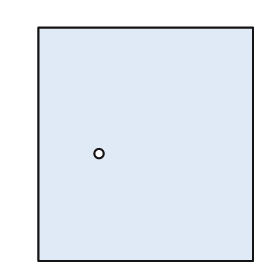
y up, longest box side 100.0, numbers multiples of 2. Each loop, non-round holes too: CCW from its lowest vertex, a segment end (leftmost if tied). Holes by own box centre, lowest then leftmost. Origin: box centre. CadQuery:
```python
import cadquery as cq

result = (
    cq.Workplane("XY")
    .moveTo(-46.0, -50.0)
    .lineTo(46.0, -50.0)
    .lineTo(46.0, 50.0)
    .lineTo(-46.0, 50.0)
    .close()
    .moveTo(-20.0, -4.0)
    .circle(2.0)
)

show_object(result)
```